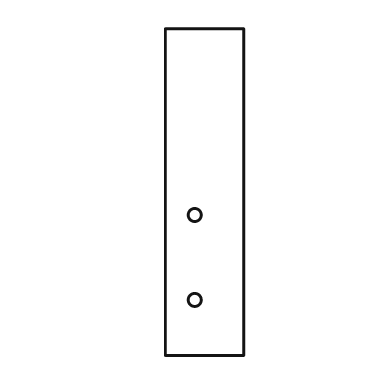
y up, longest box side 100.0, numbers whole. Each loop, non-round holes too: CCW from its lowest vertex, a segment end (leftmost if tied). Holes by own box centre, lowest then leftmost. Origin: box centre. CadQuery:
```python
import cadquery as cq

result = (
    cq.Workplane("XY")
    .moveTo(-12.0, -50.0)
    .lineTo(12.0, -50.0)
    .lineTo(12.0, 50.0)
    .lineTo(-12.0, 50.0)
    .close()
    .moveTo(-3.0, -33.0)
    .circle(2.0)
    .moveTo(-3.0, -7.0)
    .circle(2.0)
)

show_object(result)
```